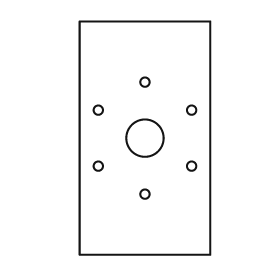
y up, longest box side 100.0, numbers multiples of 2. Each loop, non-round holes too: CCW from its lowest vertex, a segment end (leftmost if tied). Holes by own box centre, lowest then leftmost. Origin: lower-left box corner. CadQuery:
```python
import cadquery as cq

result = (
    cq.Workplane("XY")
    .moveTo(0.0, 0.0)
    .lineTo(56.0, 0.0)
    .lineTo(56.0, 100.0)
    .lineTo(0.0, 100.0)
    .close()
    .moveTo(28.0, 26.0)
    .circle(2.0)
    .moveTo(8.0, 38.0)
    .circle(2.0)
    .moveTo(48.0, 38.0)
    .circle(2.0)
    .moveTo(28.0, 50.0)
    .circle(8.0)
    .moveTo(8.0, 62.0)
    .circle(2.0)
    .moveTo(48.0, 62.0)
    .circle(2.0)
    .moveTo(28.0, 74.0)
    .circle(2.0)
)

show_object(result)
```